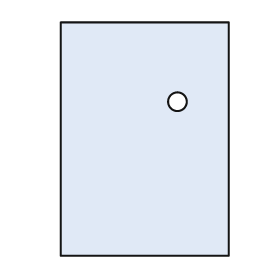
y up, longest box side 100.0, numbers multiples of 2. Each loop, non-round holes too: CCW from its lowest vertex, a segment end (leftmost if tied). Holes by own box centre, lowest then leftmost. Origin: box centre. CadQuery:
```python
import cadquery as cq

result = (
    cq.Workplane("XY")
    .moveTo(-36.0, -50.0)
    .lineTo(36.0, -50.0)
    .lineTo(36.0, 50.0)
    .lineTo(-36.0, 50.0)
    .close()
    .moveTo(14.0, 16.0)
    .circle(4.0)
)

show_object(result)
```